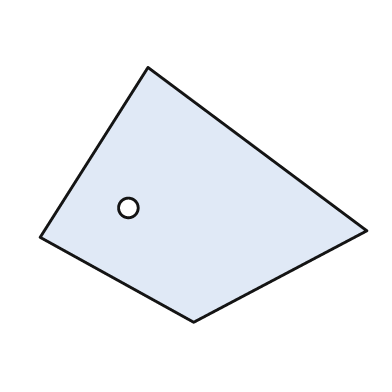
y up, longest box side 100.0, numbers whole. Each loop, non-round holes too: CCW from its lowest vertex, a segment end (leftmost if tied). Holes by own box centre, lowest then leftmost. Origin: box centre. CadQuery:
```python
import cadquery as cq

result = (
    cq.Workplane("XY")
    .moveTo(-3.0, -39.0)
    .lineTo(50.0, -11.0)
    .lineTo(-17.0, 39.0)
    .lineTo(-50.0, -13.0)
    .close()
    .moveTo(-23.0, -4.0)
    .circle(3.0)
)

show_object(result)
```